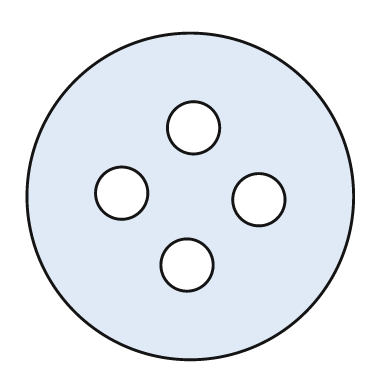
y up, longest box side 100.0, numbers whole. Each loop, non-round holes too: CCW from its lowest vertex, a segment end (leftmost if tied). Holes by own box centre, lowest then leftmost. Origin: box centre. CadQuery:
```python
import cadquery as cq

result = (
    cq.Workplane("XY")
    .moveTo(0.0, 0.0)
    .circle(50.0)
    .moveTo(-1.0, -21.0)
    .circle(8.0)
    .moveTo(21.0, -1.0)
    .circle(8.0)
    .moveTo(-21.0, 1.0)
    .circle(8.0)
    .moveTo(1.0, 21.0)
    .circle(8.0)
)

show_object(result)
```